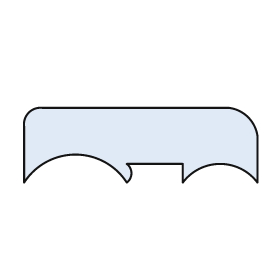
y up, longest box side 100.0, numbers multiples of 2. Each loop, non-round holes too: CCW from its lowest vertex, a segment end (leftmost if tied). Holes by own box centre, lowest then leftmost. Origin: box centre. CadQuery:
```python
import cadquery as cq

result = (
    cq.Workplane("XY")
    .moveTo(-50.0, -16.0)
    .threePointArc((-28.0, -4.0), (-6.0, -16.0))
    .threePointArc((-4.0, -12.0), (-6.0, -8.0))
    .lineTo(18.0, -8.0)
    .lineTo(18.0, -16.0)
    .threePointArc((34.0, -8.0), (50.0, -16.0))
    .lineTo(50.0, 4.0)
    .threePointArc((46.0, 12.0), (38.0, 16.0))
    .lineTo(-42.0, 16.0)
    .threePointArc((-48.0, 14.0), (-50.0, 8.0))
    .close()
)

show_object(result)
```